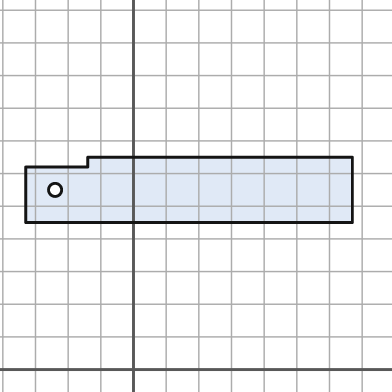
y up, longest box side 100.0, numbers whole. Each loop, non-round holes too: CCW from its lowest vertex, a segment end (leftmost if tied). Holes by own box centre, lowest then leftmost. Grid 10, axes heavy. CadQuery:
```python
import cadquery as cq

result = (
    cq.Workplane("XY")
    .moveTo(-33.0, 45.0)
    .lineTo(67.0, 45.0)
    .lineTo(67.0, 65.0)
    .lineTo(-14.0, 65.0)
    .lineTo(-14.0, 62.0)
    .lineTo(-33.0, 62.0)
    .close()
    .moveTo(-24.0, 55.0)
    .circle(2.0)
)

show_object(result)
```